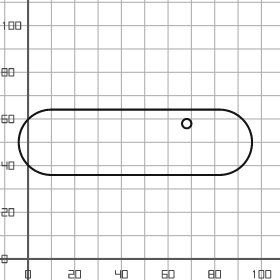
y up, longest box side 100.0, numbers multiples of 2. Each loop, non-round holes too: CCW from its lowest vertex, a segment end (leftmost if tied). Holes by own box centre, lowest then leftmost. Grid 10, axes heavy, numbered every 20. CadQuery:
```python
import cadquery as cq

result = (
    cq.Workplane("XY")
    .moveTo(10.0, 36.0)
    .lineTo(82.0, 36.0)
    .threePointArc((96.0, 50.0), (82.0, 64.0))
    .lineTo(10.0, 64.0)
    .threePointArc((-4.0, 50.0), (10.0, 36.0))
    .close()
    .moveTo(68.0, 58.0)
    .circle(2.0)
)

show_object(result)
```